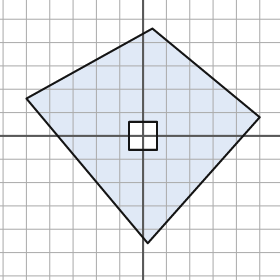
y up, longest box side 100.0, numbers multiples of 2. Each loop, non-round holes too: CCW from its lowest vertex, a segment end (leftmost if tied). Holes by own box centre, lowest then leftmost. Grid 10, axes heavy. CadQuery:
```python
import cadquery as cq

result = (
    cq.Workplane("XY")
    .moveTo(2.0, -46.0)
    .lineTo(50.0, 8.0)
    .lineTo(4.0, 46.0)
    .lineTo(-50.0, 16.0)
    .close()
    .moveTo(-6.0, -6.0)
    .lineTo(6.0, -6.0)
    .lineTo(6.0, 6.0)
    .lineTo(-6.0, 6.0)
    .close()
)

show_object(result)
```